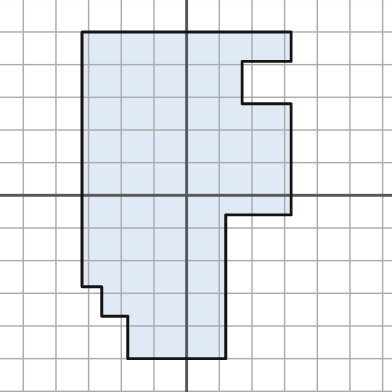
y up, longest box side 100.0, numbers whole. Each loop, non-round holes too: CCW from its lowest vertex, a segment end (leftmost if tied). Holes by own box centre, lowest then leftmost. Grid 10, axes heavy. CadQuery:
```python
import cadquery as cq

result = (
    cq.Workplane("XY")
    .moveTo(-18.0, -50.0)
    .lineTo(12.0, -50.0)
    .lineTo(12.0, -6.0)
    .lineTo(32.0, -6.0)
    .lineTo(32.0, 28.0)
    .lineTo(17.0, 28.0)
    .lineTo(17.0, 41.0)
    .lineTo(32.0, 41.0)
    .lineTo(32.0, 50.0)
    .lineTo(-32.0, 50.0)
    .lineTo(-32.0, -28.0)
    .lineTo(-26.0, -28.0)
    .lineTo(-26.0, -37.0)
    .lineTo(-18.0, -37.0)
    .close()
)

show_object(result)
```